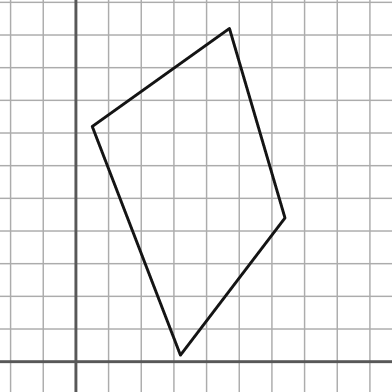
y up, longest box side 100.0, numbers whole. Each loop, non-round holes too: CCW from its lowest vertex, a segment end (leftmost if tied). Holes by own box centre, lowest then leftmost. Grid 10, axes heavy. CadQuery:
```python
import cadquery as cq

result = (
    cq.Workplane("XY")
    .moveTo(32.0, 2.0)
    .lineTo(64.0, 44.0)
    .lineTo(47.0, 102.0)
    .lineTo(5.0, 72.0)
    .close()
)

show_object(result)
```